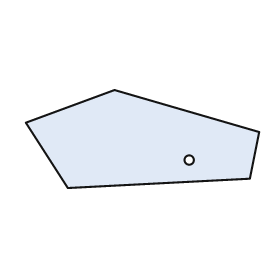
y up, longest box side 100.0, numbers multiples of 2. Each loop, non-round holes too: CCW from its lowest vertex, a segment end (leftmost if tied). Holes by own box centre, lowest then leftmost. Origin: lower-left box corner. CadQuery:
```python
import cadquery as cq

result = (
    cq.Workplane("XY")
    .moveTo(18.0, 0.0)
    .lineTo(96.0, 4.0)
    .lineTo(100.0, 24.0)
    .lineTo(38.0, 42.0)
    .lineTo(0.0, 28.0)
    .close()
    .moveTo(70.0, 12.0)
    .circle(2.0)
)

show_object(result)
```